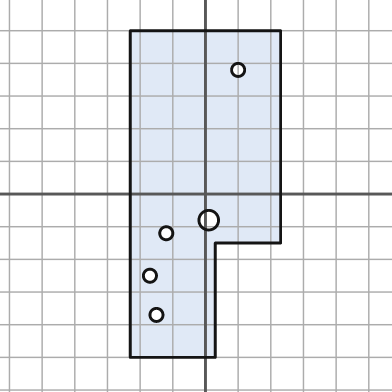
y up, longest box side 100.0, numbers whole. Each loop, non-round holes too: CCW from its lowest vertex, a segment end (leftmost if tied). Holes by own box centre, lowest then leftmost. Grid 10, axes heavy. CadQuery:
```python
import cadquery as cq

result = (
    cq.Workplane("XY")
    .moveTo(-23.0, -50.0)
    .lineTo(3.0, -50.0)
    .lineTo(3.0, -15.0)
    .lineTo(23.0, -15.0)
    .lineTo(23.0, 50.0)
    .lineTo(-23.0, 50.0)
    .close()
    .moveTo(-15.0, -37.0)
    .circle(2.0)
    .moveTo(-17.0, -25.0)
    .circle(2.0)
    .moveTo(-12.0, -12.0)
    .circle(2.0)
    .moveTo(1.0, -8.0)
    .circle(3.0)
    .moveTo(10.0, 38.0)
    .circle(2.0)
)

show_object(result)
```